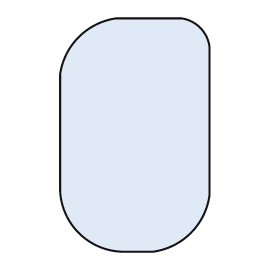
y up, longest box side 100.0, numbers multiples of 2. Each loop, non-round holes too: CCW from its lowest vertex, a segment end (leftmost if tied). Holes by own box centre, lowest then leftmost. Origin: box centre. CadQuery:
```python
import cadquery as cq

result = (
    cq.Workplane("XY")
    .moveTo(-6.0, -50.0)
    .lineTo(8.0, -50.0)
    .threePointArc((24.0, -42.0), (32.0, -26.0))
    .lineTo(32.0, 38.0)
    .threePointArc((28.0, 46.0), (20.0, 50.0))
    .lineTo(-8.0, 50.0)
    .threePointArc((-24.0, 42.0), (-32.0, 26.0))
    .lineTo(-32.0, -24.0)
    .threePointArc((-24.0, -42.0), (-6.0, -50.0))
    .close()
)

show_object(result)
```